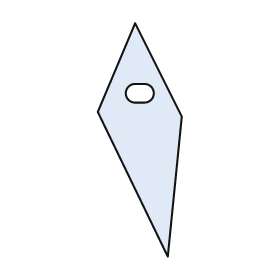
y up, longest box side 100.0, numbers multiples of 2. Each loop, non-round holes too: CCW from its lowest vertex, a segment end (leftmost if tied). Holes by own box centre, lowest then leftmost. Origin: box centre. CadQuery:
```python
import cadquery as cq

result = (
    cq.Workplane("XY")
    .moveTo(12.0, -50.0)
    .lineTo(18.0, 10.0)
    .lineTo(-2.0, 50.0)
    .lineTo(-18.0, 12.0)
    .close()
    .moveTo(-2.0, 16.0)
    .lineTo(2.0, 16.0)
    .threePointArc((6.0, 20.0), (2.0, 24.0))
    .lineTo(-2.0, 24.0)
    .threePointArc((-6.0, 20.0), (-2.0, 16.0))
    .close()
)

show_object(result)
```